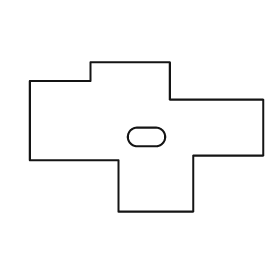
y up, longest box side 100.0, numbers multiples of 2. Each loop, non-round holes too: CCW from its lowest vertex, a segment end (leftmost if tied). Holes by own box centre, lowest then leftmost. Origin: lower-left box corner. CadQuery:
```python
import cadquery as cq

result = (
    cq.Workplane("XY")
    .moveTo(38.0, 0.0)
    .lineTo(70.0, 0.0)
    .lineTo(70.0, 24.0)
    .lineTo(100.0, 24.0)
    .lineTo(100.0, 48.0)
    .lineTo(60.0, 48.0)
    .lineTo(60.0, 64.0)
    .lineTo(26.0, 64.0)
    .lineTo(26.0, 56.0)
    .lineTo(0.0, 56.0)
    .lineTo(0.0, 22.0)
    .lineTo(38.0, 22.0)
    .close()
    .moveTo(46.0, 28.0)
    .lineTo(54.0, 28.0)
    .threePointArc((58.0, 32.0), (54.0, 36.0))
    .lineTo(46.0, 36.0)
    .threePointArc((42.0, 32.0), (46.0, 28.0))
    .close()
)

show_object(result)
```